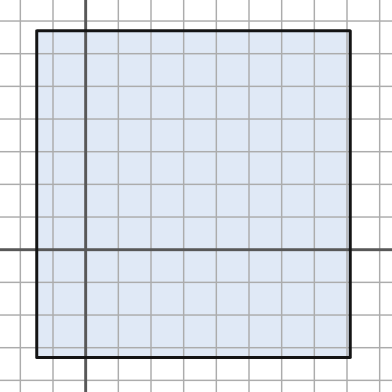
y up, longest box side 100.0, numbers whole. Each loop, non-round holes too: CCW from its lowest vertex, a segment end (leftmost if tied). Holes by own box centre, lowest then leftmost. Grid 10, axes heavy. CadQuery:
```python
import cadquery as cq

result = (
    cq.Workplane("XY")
    .moveTo(-15.0, -33.0)
    .lineTo(81.0, -33.0)
    .lineTo(81.0, 67.0)
    .lineTo(-15.0, 67.0)
    .close()
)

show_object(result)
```